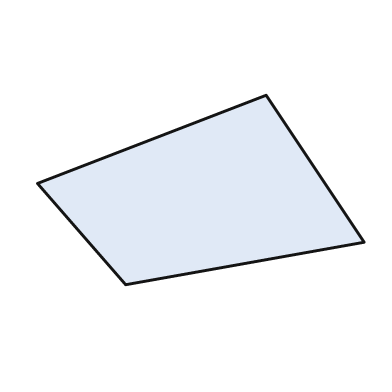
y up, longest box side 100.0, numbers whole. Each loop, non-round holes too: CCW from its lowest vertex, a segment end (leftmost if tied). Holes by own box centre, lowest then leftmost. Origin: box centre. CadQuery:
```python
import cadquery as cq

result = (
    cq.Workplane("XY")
    .moveTo(-23.0, -29.0)
    .lineTo(50.0, -16.0)
    .lineTo(20.0, 29.0)
    .lineTo(-50.0, 2.0)
    .close()
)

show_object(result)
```